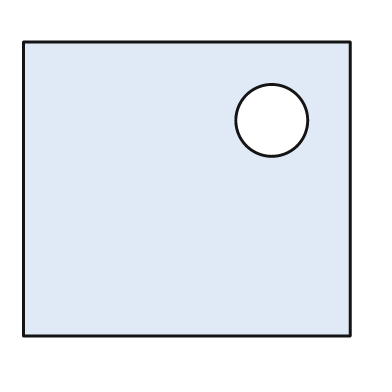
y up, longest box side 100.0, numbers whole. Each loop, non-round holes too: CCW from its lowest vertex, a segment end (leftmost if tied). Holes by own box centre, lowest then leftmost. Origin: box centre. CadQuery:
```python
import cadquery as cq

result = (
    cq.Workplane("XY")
    .moveTo(-50.0, -45.0)
    .lineTo(50.0, -45.0)
    .lineTo(50.0, 45.0)
    .lineTo(-50.0, 45.0)
    .close()
    .moveTo(26.0, 21.0)
    .circle(11.0)
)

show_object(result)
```